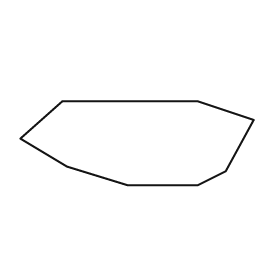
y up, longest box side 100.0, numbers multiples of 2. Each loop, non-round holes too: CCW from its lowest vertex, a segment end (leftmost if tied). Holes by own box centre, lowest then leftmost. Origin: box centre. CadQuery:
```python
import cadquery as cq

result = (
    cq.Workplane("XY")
    .moveTo(-4.0, -18.0)
    .lineTo(26.0, -18.0)
    .lineTo(38.0, -12.0)
    .lineTo(50.0, 10.0)
    .lineTo(26.0, 18.0)
    .lineTo(-32.0, 18.0)
    .lineTo(-50.0, 2.0)
    .lineTo(-30.0, -10.0)
    .close()
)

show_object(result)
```